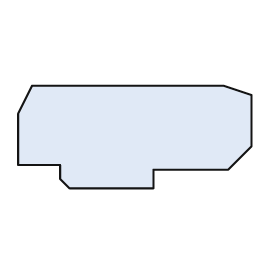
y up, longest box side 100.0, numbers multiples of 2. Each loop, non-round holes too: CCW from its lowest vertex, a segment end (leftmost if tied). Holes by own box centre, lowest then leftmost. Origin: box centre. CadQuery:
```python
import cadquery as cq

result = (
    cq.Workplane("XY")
    .moveTo(-28.0, -22.0)
    .lineTo(8.0, -22.0)
    .lineTo(8.0, -14.0)
    .lineTo(40.0, -14.0)
    .lineTo(50.0, -4.0)
    .lineTo(50.0, 18.0)
    .lineTo(38.0, 22.0)
    .lineTo(-44.0, 22.0)
    .lineTo(-50.0, 10.0)
    .lineTo(-50.0, -12.0)
    .lineTo(-32.0, -12.0)
    .lineTo(-32.0, -18.0)
    .close()
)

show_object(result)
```